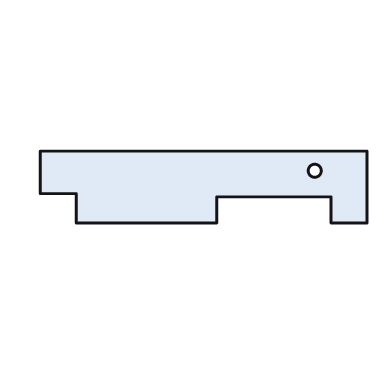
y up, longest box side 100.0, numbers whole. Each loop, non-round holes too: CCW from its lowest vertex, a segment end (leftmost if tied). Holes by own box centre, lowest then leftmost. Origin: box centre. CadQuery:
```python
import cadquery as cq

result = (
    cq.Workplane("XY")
    .moveTo(-39.0, -11.0)
    .lineTo(4.0, -11.0)
    .lineTo(4.0, -3.0)
    .lineTo(39.0, -3.0)
    .lineTo(39.0, -11.0)
    .lineTo(50.0, -11.0)
    .lineTo(50.0, 11.0)
    .lineTo(-50.0, 11.0)
    .lineTo(-50.0, -2.0)
    .lineTo(-39.0, -2.0)
    .close()
    .moveTo(34.0, 5.0)
    .circle(2.0)
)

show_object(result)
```